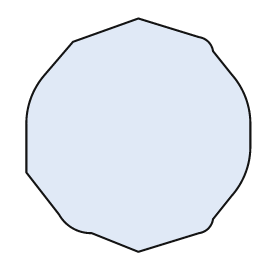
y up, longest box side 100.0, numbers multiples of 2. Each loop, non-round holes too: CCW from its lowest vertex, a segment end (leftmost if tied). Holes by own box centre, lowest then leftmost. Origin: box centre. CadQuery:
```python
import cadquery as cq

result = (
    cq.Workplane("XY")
    .moveTo(0.0, -50.0)
    .lineTo(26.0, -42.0)
    .threePointArc((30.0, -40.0), (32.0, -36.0))
    .lineTo(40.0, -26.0)
    .threePointArc((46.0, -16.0), (48.0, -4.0))
    .lineTo(48.0, 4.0)
    .threePointArc((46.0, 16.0), (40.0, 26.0))
    .lineTo(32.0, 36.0)
    .threePointArc((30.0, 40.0), (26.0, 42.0))
    .lineTo(0.0, 50.0)
    .lineTo(-28.0, 40.0)
    .lineTo(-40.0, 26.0)
    .threePointArc((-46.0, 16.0), (-48.0, 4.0))
    .lineTo(-48.0, -16.0)
    .lineTo(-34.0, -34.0)
    .threePointArc((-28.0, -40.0), (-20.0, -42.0))
    .close()
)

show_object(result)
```